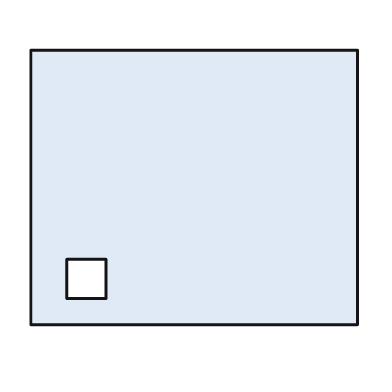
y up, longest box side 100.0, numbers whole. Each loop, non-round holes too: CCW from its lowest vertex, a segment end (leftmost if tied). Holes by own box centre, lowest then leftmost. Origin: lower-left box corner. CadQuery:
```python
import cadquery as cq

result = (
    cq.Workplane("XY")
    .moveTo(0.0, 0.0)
    .lineTo(100.0, 0.0)
    .lineTo(100.0, 84.0)
    .lineTo(0.0, 84.0)
    .close()
    .moveTo(11.0, 8.0)
    .lineTo(23.0, 8.0)
    .lineTo(23.0, 20.0)
    .lineTo(11.0, 20.0)
    .close()
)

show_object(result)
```